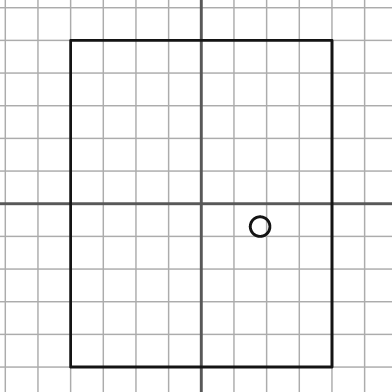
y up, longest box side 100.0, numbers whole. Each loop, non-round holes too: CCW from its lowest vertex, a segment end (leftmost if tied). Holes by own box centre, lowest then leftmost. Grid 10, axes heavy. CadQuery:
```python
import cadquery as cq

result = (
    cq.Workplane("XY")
    .moveTo(-40.0, -50.0)
    .lineTo(40.0, -50.0)
    .lineTo(40.0, 50.0)
    .lineTo(-40.0, 50.0)
    .close()
    .moveTo(18.0, -7.0)
    .circle(3.0)
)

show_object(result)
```